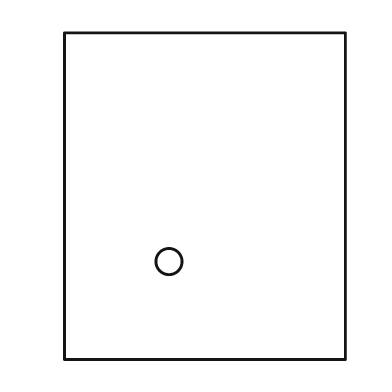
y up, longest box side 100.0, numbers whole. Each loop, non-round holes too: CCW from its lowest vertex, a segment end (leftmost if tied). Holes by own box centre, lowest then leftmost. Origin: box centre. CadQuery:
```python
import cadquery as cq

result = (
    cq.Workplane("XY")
    .moveTo(-43.0, -50.0)
    .lineTo(43.0, -50.0)
    .lineTo(43.0, 50.0)
    .lineTo(-43.0, 50.0)
    .close()
    .moveTo(-11.0, -20.0)
    .circle(4.0)
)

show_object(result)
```